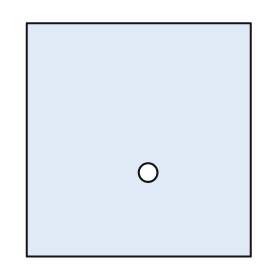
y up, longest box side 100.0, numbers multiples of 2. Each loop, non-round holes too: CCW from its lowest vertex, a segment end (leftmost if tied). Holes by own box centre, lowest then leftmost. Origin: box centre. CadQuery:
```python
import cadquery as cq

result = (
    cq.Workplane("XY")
    .moveTo(-48.0, -50.0)
    .lineTo(48.0, -50.0)
    .lineTo(48.0, 50.0)
    .lineTo(-48.0, 50.0)
    .close()
    .moveTo(4.0, -14.0)
    .circle(4.0)
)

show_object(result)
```